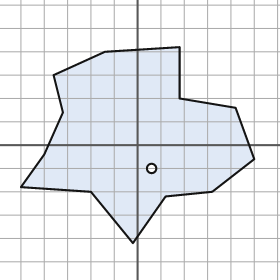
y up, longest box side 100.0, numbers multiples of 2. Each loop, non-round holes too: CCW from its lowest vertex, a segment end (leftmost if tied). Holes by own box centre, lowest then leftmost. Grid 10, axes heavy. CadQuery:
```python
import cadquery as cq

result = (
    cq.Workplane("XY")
    .moveTo(-2.0, -42.0)
    .lineTo(12.0, -22.0)
    .lineTo(32.0, -20.0)
    .lineTo(50.0, -6.0)
    .lineTo(42.0, 16.0)
    .lineTo(18.0, 20.0)
    .lineTo(18.0, 42.0)
    .lineTo(-14.0, 40.0)
    .lineTo(-36.0, 30.0)
    .lineTo(-32.0, 14.0)
    .lineTo(-40.0, -4.0)
    .lineTo(-50.0, -18.0)
    .lineTo(-20.0, -20.0)
    .close()
    .moveTo(6.0, -10.0)
    .circle(2.0)
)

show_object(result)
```